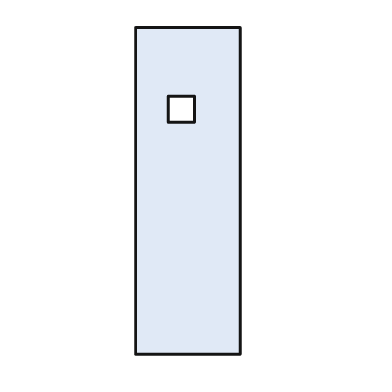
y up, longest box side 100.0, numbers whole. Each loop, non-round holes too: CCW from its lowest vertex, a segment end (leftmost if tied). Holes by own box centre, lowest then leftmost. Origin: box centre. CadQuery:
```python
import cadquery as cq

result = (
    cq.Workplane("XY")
    .moveTo(-16.0, -50.0)
    .lineTo(16.0, -50.0)
    .lineTo(16.0, 50.0)
    .lineTo(-16.0, 50.0)
    .close()
    .moveTo(-6.0, 21.0)
    .lineTo(2.0, 21.0)
    .lineTo(2.0, 29.0)
    .lineTo(-6.0, 29.0)
    .close()
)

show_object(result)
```